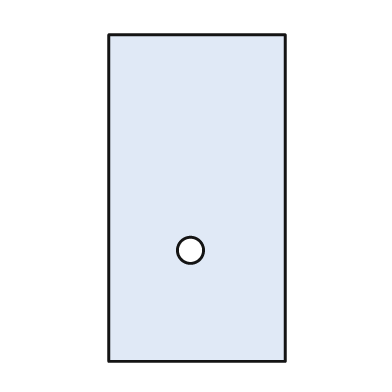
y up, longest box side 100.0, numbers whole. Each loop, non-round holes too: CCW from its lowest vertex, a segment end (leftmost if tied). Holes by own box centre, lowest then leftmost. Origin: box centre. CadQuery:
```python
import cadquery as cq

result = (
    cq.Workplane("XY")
    .moveTo(-27.0, -50.0)
    .lineTo(27.0, -50.0)
    .lineTo(27.0, 50.0)
    .lineTo(-27.0, 50.0)
    .close()
    .moveTo(-2.0, -16.0)
    .circle(4.0)
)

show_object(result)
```